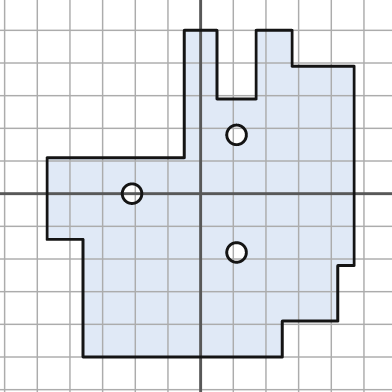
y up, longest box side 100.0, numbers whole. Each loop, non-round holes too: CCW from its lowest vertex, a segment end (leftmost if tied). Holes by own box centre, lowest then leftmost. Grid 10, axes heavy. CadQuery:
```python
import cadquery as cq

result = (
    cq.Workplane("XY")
    .moveTo(-36.0, -50.0)
    .lineTo(25.0, -50.0)
    .lineTo(25.0, -39.0)
    .lineTo(42.0, -39.0)
    .lineTo(42.0, -22.0)
    .lineTo(47.0, -22.0)
    .lineTo(47.0, 39.0)
    .lineTo(28.0, 39.0)
    .lineTo(28.0, 50.0)
    .lineTo(17.0, 50.0)
    .lineTo(17.0, 29.0)
    .lineTo(5.0, 29.0)
    .lineTo(5.0, 50.0)
    .lineTo(-5.0, 50.0)
    .lineTo(-5.0, 11.0)
    .lineTo(-47.0, 11.0)
    .lineTo(-47.0, -14.0)
    .lineTo(-36.0, -14.0)
    .close()
    .moveTo(11.0, -18.0)
    .circle(3.0)
    .moveTo(-21.0, 0.0)
    .circle(3.0)
    .moveTo(11.0, 18.0)
    .circle(3.0)
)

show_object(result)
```